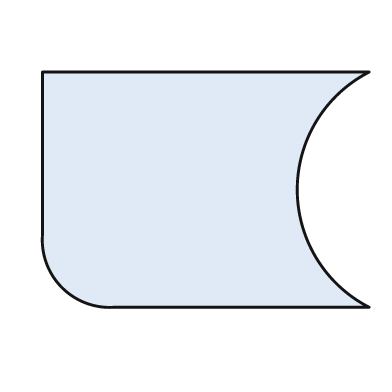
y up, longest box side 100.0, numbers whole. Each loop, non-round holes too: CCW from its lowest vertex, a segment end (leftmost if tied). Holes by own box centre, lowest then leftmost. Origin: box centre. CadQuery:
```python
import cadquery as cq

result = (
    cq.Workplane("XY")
    .moveTo(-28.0, -36.0)
    .lineTo(50.0, -36.0)
    .threePointArc((28.0, 0.0), (50.0, 36.0))
    .lineTo(-50.0, 36.0)
    .lineTo(-50.0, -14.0)
    .threePointArc((-44.0, -30.0), (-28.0, -36.0))
    .close()
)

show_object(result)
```